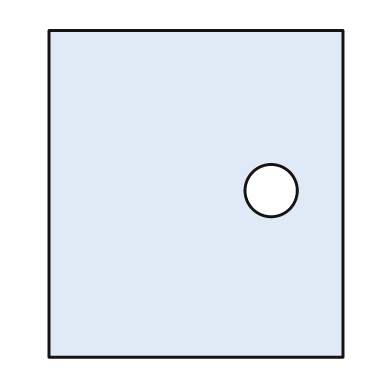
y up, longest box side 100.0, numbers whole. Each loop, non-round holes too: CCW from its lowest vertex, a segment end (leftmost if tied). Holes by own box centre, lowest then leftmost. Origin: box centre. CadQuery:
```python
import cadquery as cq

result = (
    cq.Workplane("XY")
    .moveTo(-45.0, -50.0)
    .lineTo(45.0, -50.0)
    .lineTo(45.0, 50.0)
    .lineTo(-45.0, 50.0)
    .close()
    .moveTo(23.0, 1.0)
    .circle(8.0)
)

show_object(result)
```